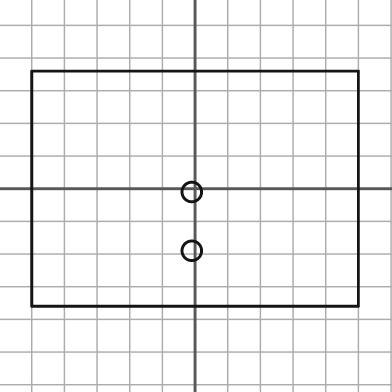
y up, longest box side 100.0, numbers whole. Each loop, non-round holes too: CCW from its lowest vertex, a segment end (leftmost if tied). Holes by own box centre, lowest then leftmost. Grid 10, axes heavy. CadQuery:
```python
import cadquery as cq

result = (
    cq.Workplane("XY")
    .moveTo(-50.0, -36.0)
    .lineTo(50.0, -36.0)
    .lineTo(50.0, 36.0)
    .lineTo(-50.0, 36.0)
    .close()
    .moveTo(-1.0, -19.0)
    .circle(3.0)
    .moveTo(-1.0, -1.0)
    .circle(3.0)
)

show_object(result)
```